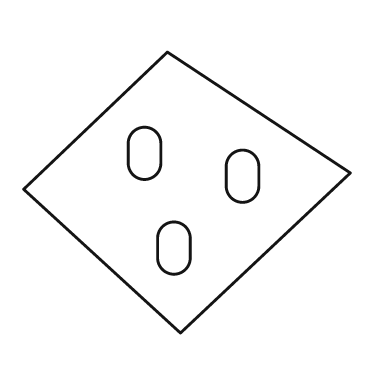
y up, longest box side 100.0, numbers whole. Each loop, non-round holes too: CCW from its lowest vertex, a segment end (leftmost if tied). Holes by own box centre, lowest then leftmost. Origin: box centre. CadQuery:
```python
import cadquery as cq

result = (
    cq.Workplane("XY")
    .moveTo(-2.0, -43.0)
    .lineTo(50.0, 6.0)
    .lineTo(-6.0, 43.0)
    .lineTo(-50.0, 1.0)
    .close()
    .moveTo(-9.0, -20.0)
    .threePointArc((-4.0, -25.0), (1.0, -20.0))
    .lineTo(1.0, -14.0)
    .threePointArc((-4.0, -9.0), (-9.0, -14.0))
    .close()
    .moveTo(12.0, 2.0)
    .threePointArc((17.0, -3.0), (22.0, 2.0))
    .lineTo(22.0, 8.0)
    .threePointArc((17.0, 13.0), (12.0, 8.0))
    .close()
    .moveTo(-18.0, 9.0)
    .threePointArc((-13.0, 4.0), (-8.0, 9.0))
    .lineTo(-8.0, 15.0)
    .threePointArc((-13.0, 20.0), (-18.0, 15.0))
    .close()
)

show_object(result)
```